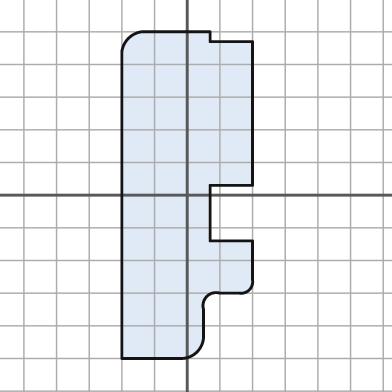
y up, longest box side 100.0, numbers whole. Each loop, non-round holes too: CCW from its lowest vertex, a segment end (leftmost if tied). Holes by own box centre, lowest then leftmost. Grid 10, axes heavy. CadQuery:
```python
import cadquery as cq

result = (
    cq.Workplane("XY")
    .moveTo(-20.0, -50.0)
    .lineTo(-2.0, -50.0)
    .threePointArc((3.0, -48.0), (5.0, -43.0))
    .lineTo(5.0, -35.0)
    .threePointArc((6.0, -31.0), (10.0, -30.0))
    .lineTo(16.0, -30.0)
    .threePointArc((19.0, -29.0), (20.0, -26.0))
    .lineTo(20.0, -14.0)
    .lineTo(7.0, -14.0)
    .lineTo(7.0, 3.0)
    .lineTo(20.0, 3.0)
    .lineTo(20.0, 47.0)
    .lineTo(7.0, 47.0)
    .lineTo(7.0, 50.0)
    .lineTo(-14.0, 50.0)
    .threePointArc((-18.0, 48.0), (-20.0, 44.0))
    .close()
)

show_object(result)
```